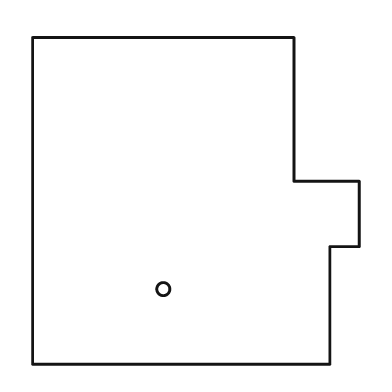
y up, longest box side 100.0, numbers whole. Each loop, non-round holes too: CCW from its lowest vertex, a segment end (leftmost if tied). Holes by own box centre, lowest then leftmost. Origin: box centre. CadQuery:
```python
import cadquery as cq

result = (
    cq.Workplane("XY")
    .moveTo(-50.0, -50.0)
    .lineTo(41.0, -50.0)
    .lineTo(41.0, -14.0)
    .lineTo(50.0, -14.0)
    .lineTo(50.0, 6.0)
    .lineTo(30.0, 6.0)
    .lineTo(30.0, 50.0)
    .lineTo(-50.0, 50.0)
    .close()
    .moveTo(-10.0, -27.0)
    .circle(2.0)
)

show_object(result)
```